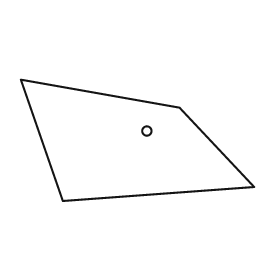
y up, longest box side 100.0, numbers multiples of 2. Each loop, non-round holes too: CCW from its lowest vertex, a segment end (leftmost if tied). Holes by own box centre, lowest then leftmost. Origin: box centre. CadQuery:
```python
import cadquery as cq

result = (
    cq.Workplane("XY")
    .moveTo(-32.0, -26.0)
    .lineTo(50.0, -20.0)
    .lineTo(18.0, 14.0)
    .lineTo(-50.0, 26.0)
    .close()
    .moveTo(4.0, 4.0)
    .circle(2.0)
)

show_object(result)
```